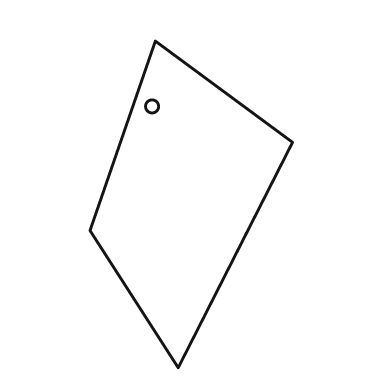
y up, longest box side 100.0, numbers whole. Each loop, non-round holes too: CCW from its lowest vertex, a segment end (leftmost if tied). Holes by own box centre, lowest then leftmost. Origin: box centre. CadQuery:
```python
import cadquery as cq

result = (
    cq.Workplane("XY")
    .moveTo(-4.0, -50.0)
    .lineTo(31.0, 19.0)
    .lineTo(-11.0, 50.0)
    .lineTo(-31.0, -8.0)
    .close()
    .moveTo(-12.0, 30.0)
    .circle(2.0)
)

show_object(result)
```